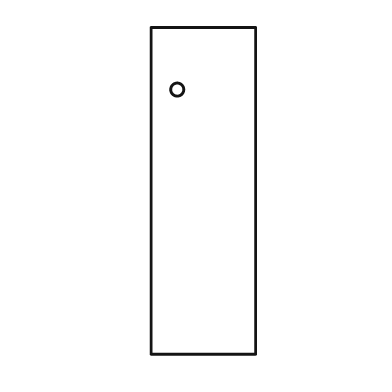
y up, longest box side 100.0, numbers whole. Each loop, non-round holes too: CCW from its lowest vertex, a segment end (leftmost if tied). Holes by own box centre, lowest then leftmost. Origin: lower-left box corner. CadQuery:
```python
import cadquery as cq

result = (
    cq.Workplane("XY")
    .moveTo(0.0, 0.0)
    .lineTo(32.0, 0.0)
    .lineTo(32.0, 100.0)
    .lineTo(0.0, 100.0)
    .close()
    .moveTo(8.0, 81.0)
    .circle(2.0)
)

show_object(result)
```